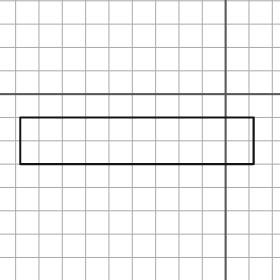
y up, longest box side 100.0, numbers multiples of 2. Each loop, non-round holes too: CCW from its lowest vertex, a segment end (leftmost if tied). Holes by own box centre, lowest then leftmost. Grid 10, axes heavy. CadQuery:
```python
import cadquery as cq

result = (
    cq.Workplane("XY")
    .moveTo(-88.0, -30.0)
    .lineTo(12.0, -30.0)
    .lineTo(12.0, -10.0)
    .lineTo(-88.0, -10.0)
    .close()
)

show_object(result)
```